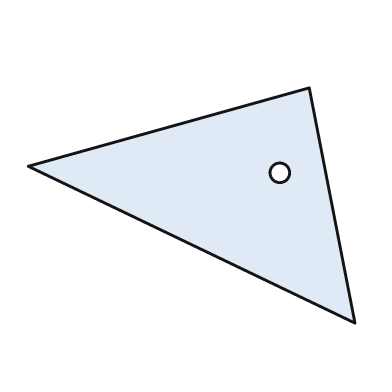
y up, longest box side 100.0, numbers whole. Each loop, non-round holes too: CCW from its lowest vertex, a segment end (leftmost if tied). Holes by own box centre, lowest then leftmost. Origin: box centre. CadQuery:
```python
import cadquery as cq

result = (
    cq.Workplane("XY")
    .moveTo(50.0, -36.0)
    .lineTo(36.0, 36.0)
    .lineTo(-50.0, 12.0)
    .close()
    .moveTo(27.0, 10.0)
    .circle(3.0)
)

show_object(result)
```